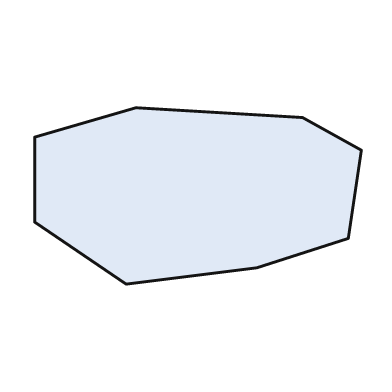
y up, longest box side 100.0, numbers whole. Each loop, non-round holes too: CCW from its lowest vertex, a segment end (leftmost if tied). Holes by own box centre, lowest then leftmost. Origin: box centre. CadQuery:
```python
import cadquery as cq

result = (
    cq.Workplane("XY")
    .moveTo(-22.0, -27.0)
    .lineTo(18.0, -22.0)
    .lineTo(46.0, -13.0)
    .lineTo(50.0, 14.0)
    .lineTo(32.0, 24.0)
    .lineTo(-19.0, 27.0)
    .lineTo(-50.0, 18.0)
    .lineTo(-50.0, -8.0)
    .close()
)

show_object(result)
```